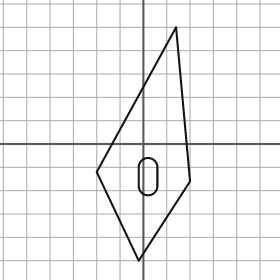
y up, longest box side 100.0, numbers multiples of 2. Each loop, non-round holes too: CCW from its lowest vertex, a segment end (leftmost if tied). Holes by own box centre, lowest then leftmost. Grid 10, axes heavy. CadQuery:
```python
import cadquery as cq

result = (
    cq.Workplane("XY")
    .moveTo(-2.0, -50.0)
    .lineTo(20.0, -16.0)
    .lineTo(14.0, 50.0)
    .lineTo(-20.0, -12.0)
    .close()
    .moveTo(-2.0, -18.0)
    .threePointArc((2.0, -22.0), (6.0, -18.0))
    .lineTo(6.0, -10.0)
    .threePointArc((2.0, -6.0), (-2.0, -10.0))
    .close()
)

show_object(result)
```